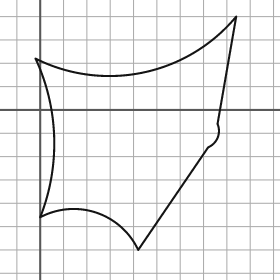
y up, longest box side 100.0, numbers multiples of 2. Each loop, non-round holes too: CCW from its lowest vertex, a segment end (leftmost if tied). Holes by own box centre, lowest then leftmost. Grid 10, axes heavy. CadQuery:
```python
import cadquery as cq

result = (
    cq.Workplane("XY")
    .moveTo(42.0, -60.0)
    .lineTo(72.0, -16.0)
    .threePointArc((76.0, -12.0), (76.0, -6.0))
    .lineTo(84.0, 40.0)
    .threePointArc((44.0, 16.0), (-2.0, 22.0))
    .threePointArc((6.0, -12.0), (0.0, -46.0))
    .threePointArc((24.0, -44.0), (42.0, -60.0))
    .close()
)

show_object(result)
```